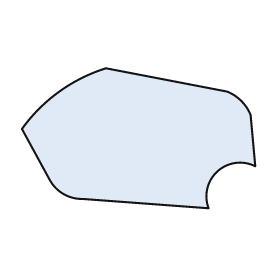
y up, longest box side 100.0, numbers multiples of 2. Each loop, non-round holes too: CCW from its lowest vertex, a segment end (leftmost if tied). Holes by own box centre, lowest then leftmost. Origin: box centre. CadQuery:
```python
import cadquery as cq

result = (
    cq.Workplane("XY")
    .moveTo(30.0, -30.0)
    .threePointArc((34.0, -14.0), (50.0, -12.0))
    .lineTo(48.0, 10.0)
    .threePointArc((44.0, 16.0), (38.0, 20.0))
    .lineTo(-14.0, 30.0)
    .threePointArc((-34.0, 20.0), (-50.0, 4.0))
    .lineTo(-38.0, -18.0)
    .threePointArc((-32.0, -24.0), (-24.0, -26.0))
    .close()
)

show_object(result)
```